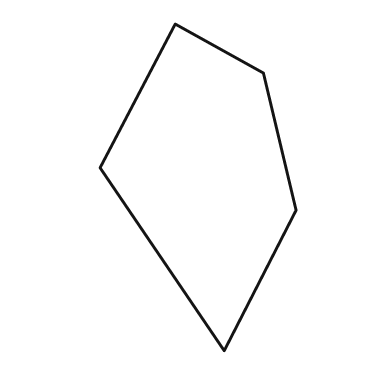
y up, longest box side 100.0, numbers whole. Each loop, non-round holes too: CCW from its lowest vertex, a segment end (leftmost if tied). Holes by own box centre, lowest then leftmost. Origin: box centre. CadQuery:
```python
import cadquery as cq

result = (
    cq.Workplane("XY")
    .moveTo(8.0, -50.0)
    .lineTo(30.0, -7.0)
    .lineTo(20.0, 35.0)
    .lineTo(-7.0, 50.0)
    .lineTo(-30.0, 6.0)
    .close()
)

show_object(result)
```